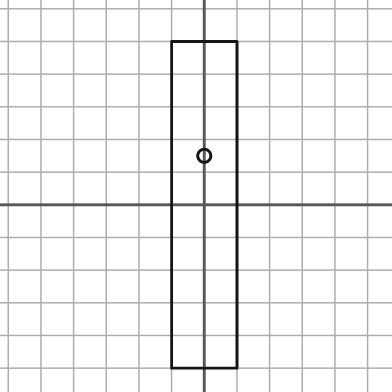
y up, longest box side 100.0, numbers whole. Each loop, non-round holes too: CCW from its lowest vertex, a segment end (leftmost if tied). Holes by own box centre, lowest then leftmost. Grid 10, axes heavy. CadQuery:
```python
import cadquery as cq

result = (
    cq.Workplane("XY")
    .moveTo(-10.0, -50.0)
    .lineTo(10.0, -50.0)
    .lineTo(10.0, 50.0)
    .lineTo(-10.0, 50.0)
    .close()
    .moveTo(0.0, 15.0)
    .circle(2.0)
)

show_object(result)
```